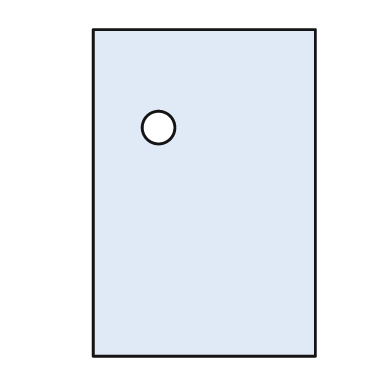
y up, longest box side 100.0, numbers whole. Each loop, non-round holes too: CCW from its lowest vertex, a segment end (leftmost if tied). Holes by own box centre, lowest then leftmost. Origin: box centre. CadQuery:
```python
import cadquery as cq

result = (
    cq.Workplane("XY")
    .moveTo(-34.0, -50.0)
    .lineTo(34.0, -50.0)
    .lineTo(34.0, 50.0)
    .lineTo(-34.0, 50.0)
    .close()
    .moveTo(-14.0, 20.0)
    .circle(5.0)
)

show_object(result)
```